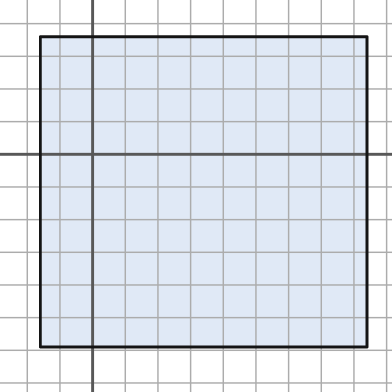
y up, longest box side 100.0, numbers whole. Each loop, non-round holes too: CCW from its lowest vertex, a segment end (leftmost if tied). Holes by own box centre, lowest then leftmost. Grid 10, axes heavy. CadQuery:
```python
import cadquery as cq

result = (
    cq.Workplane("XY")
    .moveTo(-16.0, -59.0)
    .lineTo(84.0, -59.0)
    .lineTo(84.0, 36.0)
    .lineTo(-16.0, 36.0)
    .close()
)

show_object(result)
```